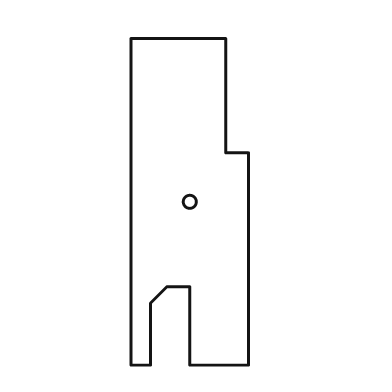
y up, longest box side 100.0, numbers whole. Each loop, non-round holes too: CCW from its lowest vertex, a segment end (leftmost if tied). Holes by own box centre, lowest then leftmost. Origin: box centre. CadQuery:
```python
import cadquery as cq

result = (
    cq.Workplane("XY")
    .moveTo(-18.0, -50.0)
    .lineTo(-12.0, -50.0)
    .lineTo(-12.0, -31.0)
    .lineTo(-7.0, -26.0)
    .lineTo(0.0, -26.0)
    .lineTo(0.0, -50.0)
    .lineTo(18.0, -50.0)
    .lineTo(18.0, 15.0)
    .lineTo(11.0, 15.0)
    .lineTo(11.0, 50.0)
    .lineTo(-18.0, 50.0)
    .close()
    .moveTo(0.0, 0.0)
    .circle(2.0)
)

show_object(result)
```